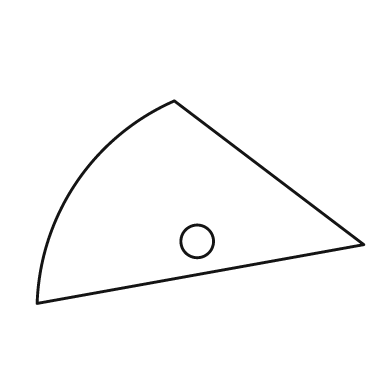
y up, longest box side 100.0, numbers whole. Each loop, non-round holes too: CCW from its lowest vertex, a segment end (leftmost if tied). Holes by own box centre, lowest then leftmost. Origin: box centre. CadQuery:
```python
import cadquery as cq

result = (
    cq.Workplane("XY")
    .moveTo(-50.0, -31.0)
    .lineTo(50.0, -13.0)
    .lineTo(-8.0, 31.0)
    .threePointArc((-38.0, 6.0), (-50.0, -31.0))
    .close()
    .moveTo(-1.0, -12.0)
    .circle(5.0)
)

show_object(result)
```